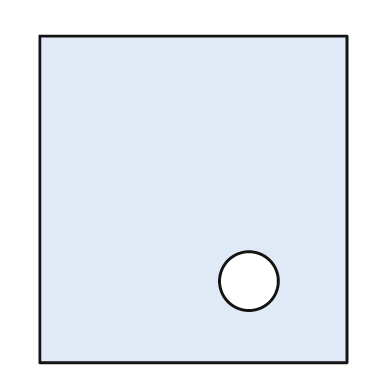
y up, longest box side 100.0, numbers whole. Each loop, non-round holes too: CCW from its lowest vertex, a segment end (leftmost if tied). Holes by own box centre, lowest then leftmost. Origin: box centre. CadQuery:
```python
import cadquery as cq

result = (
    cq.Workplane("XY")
    .moveTo(-47.0, -50.0)
    .lineTo(47.0, -50.0)
    .lineTo(47.0, 50.0)
    .lineTo(-47.0, 50.0)
    .close()
    .moveTo(17.0, -25.0)
    .circle(9.0)
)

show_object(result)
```